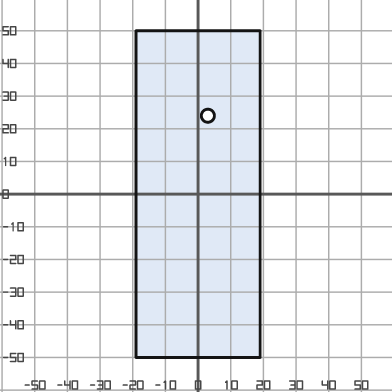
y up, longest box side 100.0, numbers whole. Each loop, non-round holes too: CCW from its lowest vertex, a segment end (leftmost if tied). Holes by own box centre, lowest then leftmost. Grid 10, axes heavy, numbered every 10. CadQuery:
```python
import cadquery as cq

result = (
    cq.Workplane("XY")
    .moveTo(-19.0, -50.0)
    .lineTo(19.0, -50.0)
    .lineTo(19.0, 50.0)
    .lineTo(-19.0, 50.0)
    .close()
    .moveTo(3.0, 24.0)
    .circle(2.0)
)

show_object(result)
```